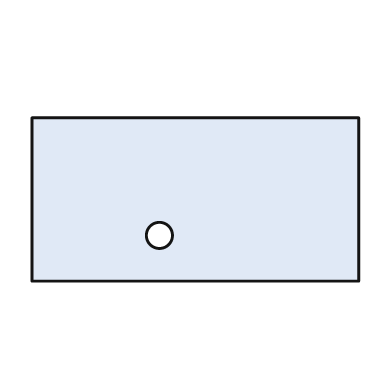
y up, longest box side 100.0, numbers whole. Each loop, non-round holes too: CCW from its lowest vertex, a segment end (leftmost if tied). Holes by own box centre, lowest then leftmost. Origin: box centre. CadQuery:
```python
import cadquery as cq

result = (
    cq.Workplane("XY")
    .moveTo(-50.0, -25.0)
    .lineTo(50.0, -25.0)
    .lineTo(50.0, 25.0)
    .lineTo(-50.0, 25.0)
    .close()
    .moveTo(-11.0, -11.0)
    .circle(4.0)
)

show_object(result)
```